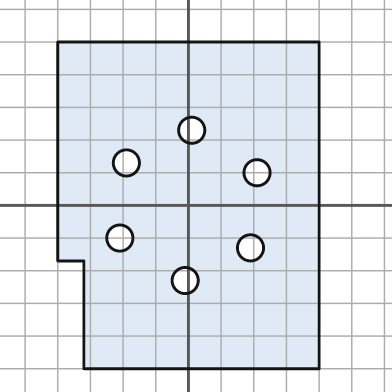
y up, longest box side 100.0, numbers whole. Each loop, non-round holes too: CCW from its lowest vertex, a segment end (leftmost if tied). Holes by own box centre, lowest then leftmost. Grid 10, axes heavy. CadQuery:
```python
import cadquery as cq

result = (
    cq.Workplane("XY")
    .moveTo(-32.0, -50.0)
    .lineTo(40.0, -50.0)
    .lineTo(40.0, 50.0)
    .lineTo(-40.0, 50.0)
    .lineTo(-40.0, -17.0)
    .lineTo(-32.0, -17.0)
    .close()
    .moveTo(-1.0, -23.0)
    .circle(4.0)
    .moveTo(19.0, -13.0)
    .circle(4.0)
    .moveTo(-21.0, -10.0)
    .circle(4.0)
    .moveTo(21.0, 10.0)
    .circle(4.0)
    .moveTo(-19.0, 13.0)
    .circle(4.0)
    .moveTo(1.0, 23.0)
    .circle(4.0)
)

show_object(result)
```